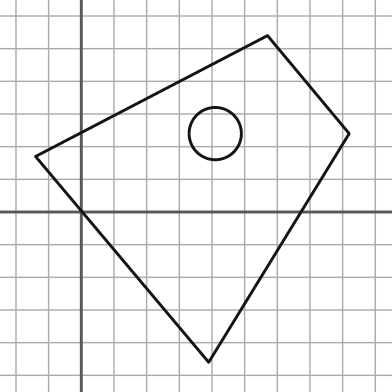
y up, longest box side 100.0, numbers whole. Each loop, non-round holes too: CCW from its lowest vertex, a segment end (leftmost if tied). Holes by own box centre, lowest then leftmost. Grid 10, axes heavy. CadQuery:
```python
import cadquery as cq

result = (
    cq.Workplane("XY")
    .moveTo(39.0, -46.0)
    .lineTo(82.0, 24.0)
    .lineTo(57.0, 54.0)
    .lineTo(-14.0, 17.0)
    .close()
    .moveTo(41.0, 24.0)
    .circle(8.0)
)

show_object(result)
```